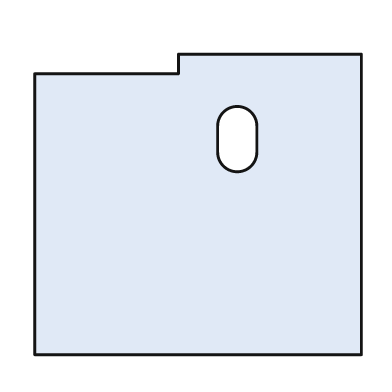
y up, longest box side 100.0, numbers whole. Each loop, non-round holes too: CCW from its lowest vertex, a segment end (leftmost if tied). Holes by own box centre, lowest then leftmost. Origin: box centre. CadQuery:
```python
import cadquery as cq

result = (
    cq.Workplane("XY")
    .moveTo(-50.0, -46.0)
    .lineTo(50.0, -46.0)
    .lineTo(50.0, 46.0)
    .lineTo(-6.0, 46.0)
    .lineTo(-6.0, 40.0)
    .lineTo(-50.0, 40.0)
    .close()
    .moveTo(6.0, 16.0)
    .threePointArc((12.0, 10.0), (18.0, 16.0))
    .lineTo(18.0, 24.0)
    .threePointArc((12.0, 30.0), (6.0, 24.0))
    .close()
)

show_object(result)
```